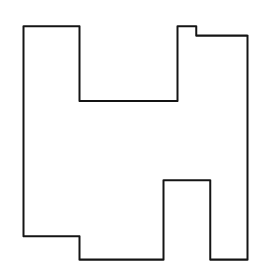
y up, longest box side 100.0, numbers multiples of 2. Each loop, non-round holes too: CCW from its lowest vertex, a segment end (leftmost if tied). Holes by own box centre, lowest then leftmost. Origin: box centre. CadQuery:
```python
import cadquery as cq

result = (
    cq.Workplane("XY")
    .moveTo(-24.0, -50.0)
    .lineTo(12.0, -50.0)
    .lineTo(12.0, -16.0)
    .lineTo(32.0, -16.0)
    .lineTo(32.0, -50.0)
    .lineTo(48.0, -50.0)
    .lineTo(48.0, 46.0)
    .lineTo(26.0, 46.0)
    .lineTo(26.0, 50.0)
    .lineTo(18.0, 50.0)
    .lineTo(18.0, 18.0)
    .lineTo(-24.0, 18.0)
    .lineTo(-24.0, 50.0)
    .lineTo(-48.0, 50.0)
    .lineTo(-48.0, -40.0)
    .lineTo(-24.0, -40.0)
    .close()
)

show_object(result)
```